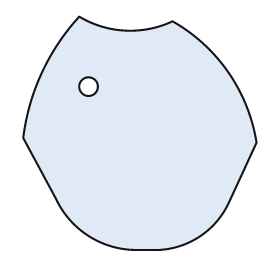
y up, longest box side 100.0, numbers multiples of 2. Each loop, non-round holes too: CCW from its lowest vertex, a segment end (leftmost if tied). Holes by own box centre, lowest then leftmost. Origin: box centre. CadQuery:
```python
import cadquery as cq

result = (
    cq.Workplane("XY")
    .moveTo(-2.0, -50.0)
    .lineTo(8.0, -50.0)
    .threePointArc((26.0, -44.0), (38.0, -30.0))
    .lineTo(50.0, -4.0)
    .threePointArc((38.0, 26.0), (14.0, 48.0))
    .threePointArc((-6.0, 44.0), (-26.0, 50.0))
    .threePointArc((-42.0, 26.0), (-50.0, -2.0))
    .lineTo(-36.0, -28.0)
    .threePointArc((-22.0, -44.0), (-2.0, -50.0))
    .close()
    .moveTo(-22.0, 20.0)
    .circle(4.0)
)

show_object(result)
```